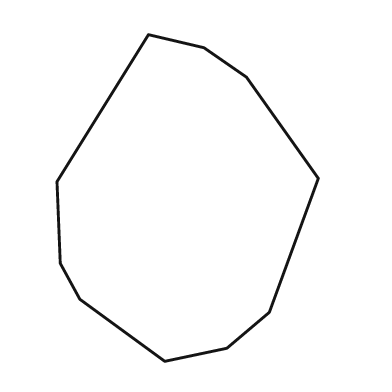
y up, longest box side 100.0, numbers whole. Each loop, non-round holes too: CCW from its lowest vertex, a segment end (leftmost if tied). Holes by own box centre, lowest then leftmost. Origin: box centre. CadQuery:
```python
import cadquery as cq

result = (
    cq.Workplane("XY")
    .moveTo(-7.0, -50.0)
    .lineTo(12.0, -46.0)
    .lineTo(25.0, -35.0)
    .lineTo(40.0, 6.0)
    .lineTo(18.0, 37.0)
    .lineTo(5.0, 46.0)
    .lineTo(-12.0, 50.0)
    .lineTo(-40.0, 5.0)
    .lineTo(-39.0, -20.0)
    .lineTo(-33.0, -31.0)
    .close()
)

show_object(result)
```